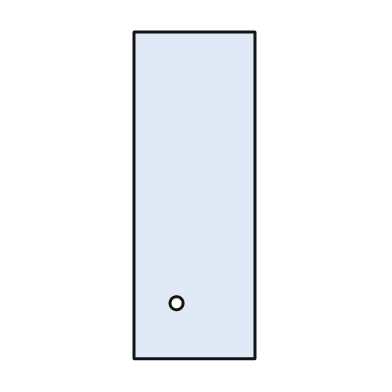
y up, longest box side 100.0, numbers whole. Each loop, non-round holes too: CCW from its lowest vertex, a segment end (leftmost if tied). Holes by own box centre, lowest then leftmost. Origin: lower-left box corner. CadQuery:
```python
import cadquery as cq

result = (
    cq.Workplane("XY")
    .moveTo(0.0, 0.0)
    .lineTo(37.0, 0.0)
    .lineTo(37.0, 100.0)
    .lineTo(0.0, 100.0)
    .close()
    .moveTo(13.0, 17.0)
    .circle(2.0)
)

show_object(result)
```